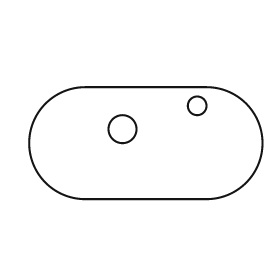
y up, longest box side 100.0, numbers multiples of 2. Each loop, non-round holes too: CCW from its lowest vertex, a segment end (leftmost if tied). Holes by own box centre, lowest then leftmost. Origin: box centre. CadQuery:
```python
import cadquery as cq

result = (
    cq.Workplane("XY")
    .moveTo(-26.0, -24.0)
    .lineTo(26.0, -24.0)
    .threePointArc((50.0, 0.0), (26.0, 24.0))
    .lineTo(-26.0, 24.0)
    .threePointArc((-50.0, 0.0), (-26.0, -24.0))
    .close()
    .moveTo(-10.0, 6.0)
    .circle(6.0)
    .moveTo(22.0, 16.0)
    .circle(4.0)
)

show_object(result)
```